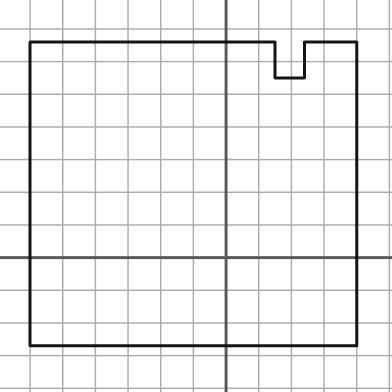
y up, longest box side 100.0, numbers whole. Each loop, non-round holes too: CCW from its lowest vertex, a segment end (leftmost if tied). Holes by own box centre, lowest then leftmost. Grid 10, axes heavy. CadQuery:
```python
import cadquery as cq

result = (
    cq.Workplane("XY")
    .moveTo(-60.0, -27.0)
    .lineTo(40.0, -27.0)
    .lineTo(40.0, 66.0)
    .lineTo(24.0, 66.0)
    .lineTo(24.0, 55.0)
    .lineTo(15.0, 55.0)
    .lineTo(15.0, 66.0)
    .lineTo(-60.0, 66.0)
    .close()
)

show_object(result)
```